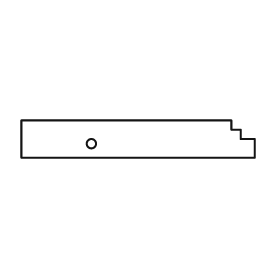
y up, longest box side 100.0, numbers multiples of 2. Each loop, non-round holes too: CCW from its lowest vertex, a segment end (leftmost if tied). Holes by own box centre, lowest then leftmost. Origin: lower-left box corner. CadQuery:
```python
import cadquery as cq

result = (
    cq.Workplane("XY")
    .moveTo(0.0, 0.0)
    .lineTo(100.0, 0.0)
    .lineTo(100.0, 8.0)
    .lineTo(94.0, 8.0)
    .lineTo(94.0, 12.0)
    .lineTo(90.0, 12.0)
    .lineTo(90.0, 16.0)
    .lineTo(0.0, 16.0)
    .close()
    .moveTo(30.0, 6.0)
    .circle(2.0)
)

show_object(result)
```